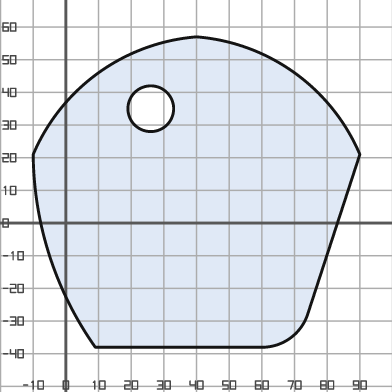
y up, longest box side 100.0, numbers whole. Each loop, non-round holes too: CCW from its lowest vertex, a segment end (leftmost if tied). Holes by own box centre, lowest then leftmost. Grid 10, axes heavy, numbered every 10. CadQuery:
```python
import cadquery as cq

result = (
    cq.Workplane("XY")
    .moveTo(9.0, -38.0)
    .lineTo(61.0, -38.0)
    .threePointArc((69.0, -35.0), (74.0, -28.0))
    .lineTo(90.0, 21.0)
    .threePointArc((70.0, 46.0), (40.0, 57.0))
    .threePointArc((10.0, 46.0), (-10.0, 21.0))
    .threePointArc((-5.0, -10.0), (9.0, -38.0))
    .close()
    .moveTo(26.0, 35.0)
    .circle(7.0)
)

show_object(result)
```